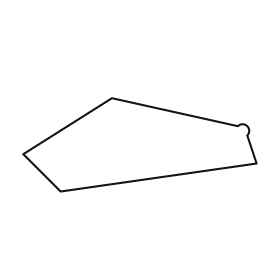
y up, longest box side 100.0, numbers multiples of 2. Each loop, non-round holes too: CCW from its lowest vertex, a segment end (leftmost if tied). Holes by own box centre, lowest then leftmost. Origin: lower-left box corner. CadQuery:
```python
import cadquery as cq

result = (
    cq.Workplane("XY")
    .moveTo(16.0, 0.0)
    .lineTo(100.0, 12.0)
    .lineTo(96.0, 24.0)
    .threePointArc((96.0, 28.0), (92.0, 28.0))
    .lineTo(38.0, 40.0)
    .lineTo(0.0, 16.0)
    .close()
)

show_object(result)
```